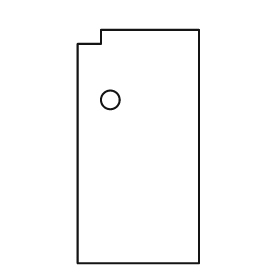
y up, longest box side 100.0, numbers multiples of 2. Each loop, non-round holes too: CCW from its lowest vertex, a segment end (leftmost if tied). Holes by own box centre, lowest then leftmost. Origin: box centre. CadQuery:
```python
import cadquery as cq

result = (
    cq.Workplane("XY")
    .moveTo(-26.0, -50.0)
    .lineTo(26.0, -50.0)
    .lineTo(26.0, 50.0)
    .lineTo(-16.0, 50.0)
    .lineTo(-16.0, 44.0)
    .lineTo(-26.0, 44.0)
    .close()
    .moveTo(-12.0, 20.0)
    .circle(4.0)
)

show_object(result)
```